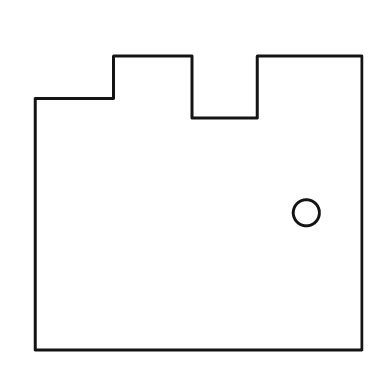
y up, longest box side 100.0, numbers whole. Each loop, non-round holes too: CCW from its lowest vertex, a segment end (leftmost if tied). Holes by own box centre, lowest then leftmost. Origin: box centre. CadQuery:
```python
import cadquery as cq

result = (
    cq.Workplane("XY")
    .moveTo(-50.0, -45.0)
    .lineTo(50.0, -45.0)
    .lineTo(50.0, 45.0)
    .lineTo(18.0, 45.0)
    .lineTo(18.0, 26.0)
    .lineTo(-2.0, 26.0)
    .lineTo(-2.0, 45.0)
    .lineTo(-26.0, 45.0)
    .lineTo(-26.0, 32.0)
    .lineTo(-50.0, 32.0)
    .close()
    .moveTo(33.0, -3.0)
    .circle(4.0)
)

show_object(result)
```